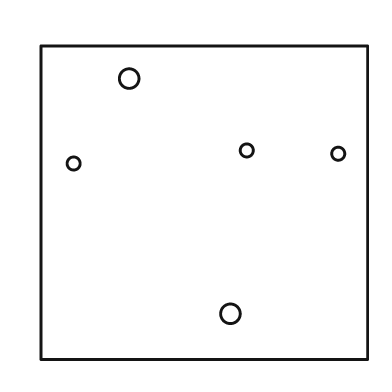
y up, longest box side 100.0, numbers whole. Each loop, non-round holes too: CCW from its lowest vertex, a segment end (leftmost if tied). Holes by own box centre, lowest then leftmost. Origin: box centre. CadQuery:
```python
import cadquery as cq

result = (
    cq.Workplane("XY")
    .moveTo(-50.0, -48.0)
    .lineTo(50.0, -48.0)
    .lineTo(50.0, 48.0)
    .lineTo(-50.0, 48.0)
    .close()
    .moveTo(8.0, -34.0)
    .circle(3.0)
    .moveTo(-40.0, 12.0)
    .circle(2.0)
    .moveTo(41.0, 15.0)
    .circle(2.0)
    .moveTo(13.0, 16.0)
    .circle(2.0)
    .moveTo(-23.0, 38.0)
    .circle(3.0)
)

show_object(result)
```